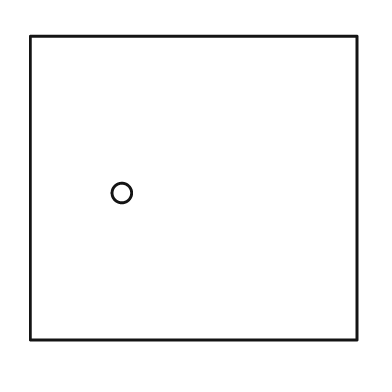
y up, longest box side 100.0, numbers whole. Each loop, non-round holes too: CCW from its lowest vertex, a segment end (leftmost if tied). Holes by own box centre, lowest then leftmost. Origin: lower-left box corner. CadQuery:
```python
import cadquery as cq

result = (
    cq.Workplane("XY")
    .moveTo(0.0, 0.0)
    .lineTo(100.0, 0.0)
    .lineTo(100.0, 93.0)
    .lineTo(0.0, 93.0)
    .close()
    .moveTo(28.0, 45.0)
    .circle(3.0)
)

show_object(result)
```